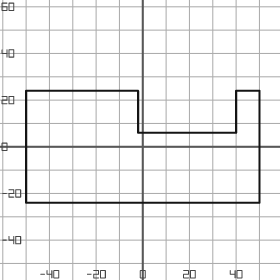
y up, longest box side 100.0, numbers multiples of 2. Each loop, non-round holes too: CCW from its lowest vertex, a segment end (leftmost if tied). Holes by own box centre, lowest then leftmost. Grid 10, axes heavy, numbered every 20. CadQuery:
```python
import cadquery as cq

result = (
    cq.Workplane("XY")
    .moveTo(-50.0, -24.0)
    .lineTo(50.0, -24.0)
    .lineTo(50.0, 24.0)
    .lineTo(40.0, 24.0)
    .lineTo(40.0, 6.0)
    .lineTo(-2.0, 6.0)
    .lineTo(-2.0, 24.0)
    .lineTo(-50.0, 24.0)
    .close()
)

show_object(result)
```